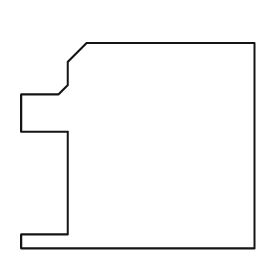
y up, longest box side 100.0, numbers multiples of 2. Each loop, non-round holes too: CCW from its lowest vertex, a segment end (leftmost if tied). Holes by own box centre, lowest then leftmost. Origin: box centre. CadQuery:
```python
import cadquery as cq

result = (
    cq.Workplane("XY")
    .moveTo(-50.0, -44.0)
    .lineTo(50.0, -44.0)
    .lineTo(50.0, 44.0)
    .lineTo(-22.0, 44.0)
    .lineTo(-30.0, 36.0)
    .lineTo(-30.0, 26.0)
    .lineTo(-34.0, 22.0)
    .lineTo(-50.0, 22.0)
    .lineTo(-50.0, 6.0)
    .lineTo(-30.0, 6.0)
    .lineTo(-30.0, -38.0)
    .lineTo(-50.0, -38.0)
    .close()
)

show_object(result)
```